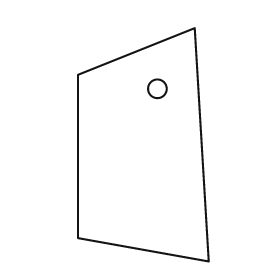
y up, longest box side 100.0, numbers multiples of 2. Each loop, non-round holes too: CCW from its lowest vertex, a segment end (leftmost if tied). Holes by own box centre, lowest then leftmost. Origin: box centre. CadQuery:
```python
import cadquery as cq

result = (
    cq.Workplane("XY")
    .moveTo(28.0, -50.0)
    .lineTo(22.0, 50.0)
    .lineTo(-28.0, 30.0)
    .lineTo(-28.0, -40.0)
    .close()
    .moveTo(6.0, 24.0)
    .circle(4.0)
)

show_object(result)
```